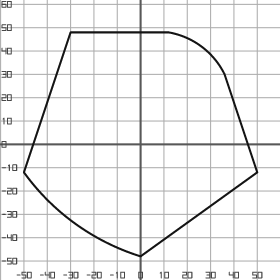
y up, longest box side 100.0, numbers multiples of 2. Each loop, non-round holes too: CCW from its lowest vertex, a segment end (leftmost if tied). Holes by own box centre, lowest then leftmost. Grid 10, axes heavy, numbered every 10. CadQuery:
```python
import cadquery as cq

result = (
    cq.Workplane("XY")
    .moveTo(0.0, -48.0)
    .lineTo(50.0, -12.0)
    .lineTo(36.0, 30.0)
    .threePointArc((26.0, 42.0), (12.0, 48.0))
    .lineTo(-30.0, 48.0)
    .lineTo(-50.0, -12.0)
    .threePointArc((-28.0, -34.0), (0.0, -48.0))
    .close()
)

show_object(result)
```